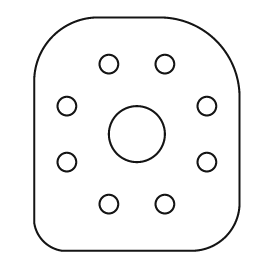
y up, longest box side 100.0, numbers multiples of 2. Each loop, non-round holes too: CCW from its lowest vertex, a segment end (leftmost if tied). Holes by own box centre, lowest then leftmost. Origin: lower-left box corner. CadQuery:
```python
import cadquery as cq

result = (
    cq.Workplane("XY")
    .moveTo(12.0, 0.0)
    .lineTo(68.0, 0.0)
    .threePointArc((82.0, 6.0), (88.0, 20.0))
    .lineTo(88.0, 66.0)
    .threePointArc((78.0, 90.0), (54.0, 100.0))
    .lineTo(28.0, 100.0)
    .threePointArc((8.0, 92.0), (0.0, 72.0))
    .lineTo(0.0, 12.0)
    .threePointArc((4.0, 4.0), (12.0, 0.0))
    .close()
    .moveTo(32.0, 20.0)
    .circle(4.0)
    .moveTo(56.0, 20.0)
    .circle(4.0)
    .moveTo(14.0, 38.0)
    .circle(4.0)
    .moveTo(74.0, 38.0)
    .circle(4.0)
    .moveTo(44.0, 50.0)
    .circle(12.0)
    .moveTo(14.0, 62.0)
    .circle(4.0)
    .moveTo(74.0, 62.0)
    .circle(4.0)
    .moveTo(32.0, 80.0)
    .circle(4.0)
    .moveTo(56.0, 80.0)
    .circle(4.0)
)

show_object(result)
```